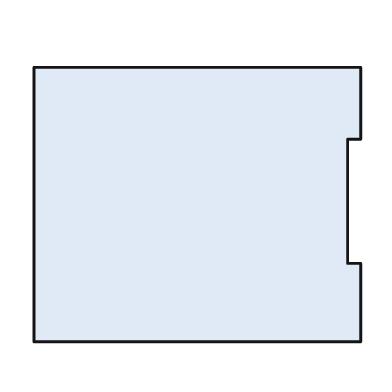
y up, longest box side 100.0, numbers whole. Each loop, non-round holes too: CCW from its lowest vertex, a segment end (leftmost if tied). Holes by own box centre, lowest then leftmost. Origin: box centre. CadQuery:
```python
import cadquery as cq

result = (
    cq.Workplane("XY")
    .moveTo(-50.0, -42.0)
    .lineTo(50.0, -42.0)
    .lineTo(50.0, -18.0)
    .lineTo(46.0, -18.0)
    .lineTo(46.0, 20.0)
    .lineTo(50.0, 20.0)
    .lineTo(50.0, 42.0)
    .lineTo(-50.0, 42.0)
    .close()
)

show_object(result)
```